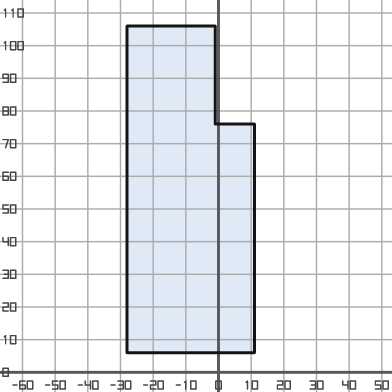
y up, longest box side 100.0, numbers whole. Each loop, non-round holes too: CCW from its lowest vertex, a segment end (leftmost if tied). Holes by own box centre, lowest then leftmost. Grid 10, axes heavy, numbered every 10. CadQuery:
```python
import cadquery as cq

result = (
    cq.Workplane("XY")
    .moveTo(-28.0, 6.0)
    .lineTo(11.0, 6.0)
    .lineTo(11.0, 76.0)
    .lineTo(-1.0, 76.0)
    .lineTo(-1.0, 106.0)
    .lineTo(-28.0, 106.0)
    .close()
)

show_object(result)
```